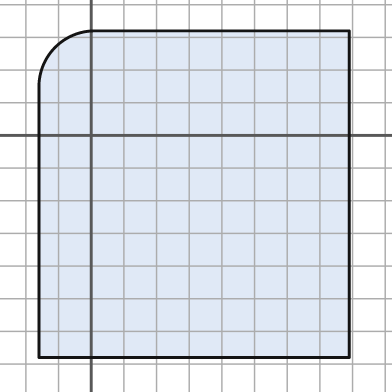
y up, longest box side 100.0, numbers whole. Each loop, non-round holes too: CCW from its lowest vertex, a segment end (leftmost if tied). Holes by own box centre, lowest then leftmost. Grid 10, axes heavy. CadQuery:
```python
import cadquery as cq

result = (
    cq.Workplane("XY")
    .moveTo(-16.0, -68.0)
    .lineTo(79.0, -68.0)
    .lineTo(79.0, 32.0)
    .lineTo(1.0, 32.0)
    .threePointArc((-11.0, 27.0), (-16.0, 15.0))
    .close()
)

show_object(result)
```